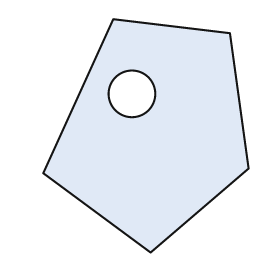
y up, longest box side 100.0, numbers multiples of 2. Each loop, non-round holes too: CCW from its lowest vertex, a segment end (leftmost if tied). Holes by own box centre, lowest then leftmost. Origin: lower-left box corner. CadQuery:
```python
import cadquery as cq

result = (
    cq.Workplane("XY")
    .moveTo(46.0, 0.0)
    .lineTo(88.0, 36.0)
    .lineTo(80.0, 94.0)
    .lineTo(30.0, 100.0)
    .lineTo(0.0, 34.0)
    .close()
    .moveTo(38.0, 68.0)
    .circle(10.0)
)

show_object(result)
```